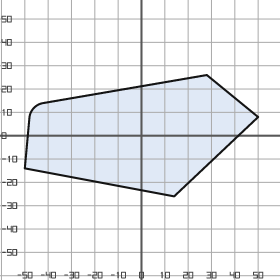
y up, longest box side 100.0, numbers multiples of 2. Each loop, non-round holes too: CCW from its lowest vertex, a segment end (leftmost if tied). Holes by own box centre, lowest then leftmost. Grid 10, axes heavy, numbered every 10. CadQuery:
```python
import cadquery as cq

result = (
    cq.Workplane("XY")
    .moveTo(14.0, -26.0)
    .lineTo(50.0, 8.0)
    .lineTo(28.0, 26.0)
    .lineTo(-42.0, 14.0)
    .threePointArc((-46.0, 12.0), (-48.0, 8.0))
    .lineTo(-50.0, -14.0)
    .close()
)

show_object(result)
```